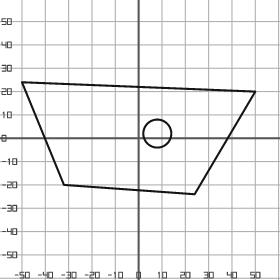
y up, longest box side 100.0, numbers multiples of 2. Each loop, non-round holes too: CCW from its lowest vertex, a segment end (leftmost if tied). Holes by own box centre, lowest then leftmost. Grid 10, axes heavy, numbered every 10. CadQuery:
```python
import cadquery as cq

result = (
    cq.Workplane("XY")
    .moveTo(24.0, -24.0)
    .lineTo(50.0, 20.0)
    .lineTo(-50.0, 24.0)
    .lineTo(-32.0, -20.0)
    .close()
    .moveTo(8.0, 2.0)
    .circle(6.0)
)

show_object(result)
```